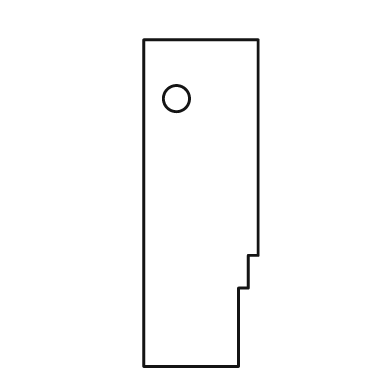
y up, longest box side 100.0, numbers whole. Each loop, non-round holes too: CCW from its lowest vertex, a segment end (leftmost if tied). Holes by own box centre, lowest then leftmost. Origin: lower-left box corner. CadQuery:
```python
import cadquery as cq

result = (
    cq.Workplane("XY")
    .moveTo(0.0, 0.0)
    .lineTo(29.0, 0.0)
    .lineTo(29.0, 24.0)
    .lineTo(32.0, 24.0)
    .lineTo(32.0, 34.0)
    .lineTo(35.0, 34.0)
    .lineTo(35.0, 100.0)
    .lineTo(0.0, 100.0)
    .close()
    .moveTo(10.0, 82.0)
    .circle(4.0)
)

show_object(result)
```